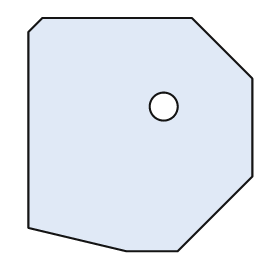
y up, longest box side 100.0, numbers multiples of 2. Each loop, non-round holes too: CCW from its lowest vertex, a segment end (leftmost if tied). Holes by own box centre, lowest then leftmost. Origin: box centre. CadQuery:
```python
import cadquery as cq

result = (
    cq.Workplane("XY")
    .moveTo(-6.0, -50.0)
    .lineTo(16.0, -50.0)
    .lineTo(48.0, -18.0)
    .lineTo(48.0, 24.0)
    .lineTo(22.0, 50.0)
    .lineTo(-42.0, 50.0)
    .lineTo(-48.0, 44.0)
    .lineTo(-48.0, -40.0)
    .close()
    .moveTo(10.0, 12.0)
    .circle(6.0)
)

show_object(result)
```